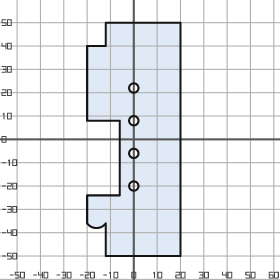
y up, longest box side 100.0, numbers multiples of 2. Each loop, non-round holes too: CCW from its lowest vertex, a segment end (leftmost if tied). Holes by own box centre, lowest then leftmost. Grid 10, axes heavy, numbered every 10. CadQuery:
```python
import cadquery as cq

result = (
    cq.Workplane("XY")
    .moveTo(-12.0, -50.0)
    .lineTo(20.0, -50.0)
    .lineTo(20.0, 50.0)
    .lineTo(-12.0, 50.0)
    .lineTo(-12.0, 40.0)
    .lineTo(-20.0, 40.0)
    .lineTo(-20.0, 8.0)
    .lineTo(-6.0, 8.0)
    .lineTo(-6.0, -24.0)
    .lineTo(-20.0, -24.0)
    .lineTo(-20.0, -36.0)
    .threePointArc((-16.0, -38.0), (-12.0, -36.0))
    .close()
    .moveTo(0.0, -20.0)
    .circle(2.0)
    .moveTo(0.0, -6.0)
    .circle(2.0)
    .moveTo(0.0, 8.0)
    .circle(2.0)
    .moveTo(0.0, 22.0)
    .circle(2.0)
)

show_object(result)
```